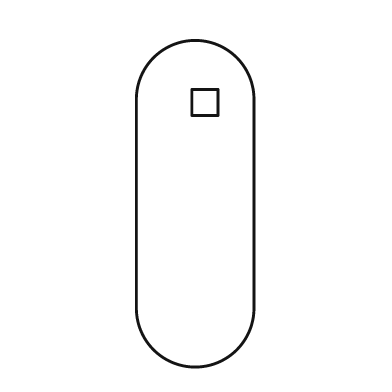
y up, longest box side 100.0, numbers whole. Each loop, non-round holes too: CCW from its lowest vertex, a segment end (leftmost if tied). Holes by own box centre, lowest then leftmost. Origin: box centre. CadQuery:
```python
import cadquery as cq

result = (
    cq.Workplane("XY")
    .moveTo(-18.0, -32.0)
    .threePointArc((0.0, -50.0), (18.0, -32.0))
    .lineTo(18.0, 32.0)
    .threePointArc((0.0, 50.0), (-18.0, 32.0))
    .close()
    .moveTo(-1.0, 27.0)
    .lineTo(7.0, 27.0)
    .lineTo(7.0, 35.0)
    .lineTo(-1.0, 35.0)
    .close()
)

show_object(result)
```